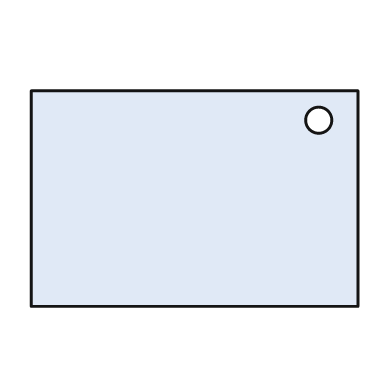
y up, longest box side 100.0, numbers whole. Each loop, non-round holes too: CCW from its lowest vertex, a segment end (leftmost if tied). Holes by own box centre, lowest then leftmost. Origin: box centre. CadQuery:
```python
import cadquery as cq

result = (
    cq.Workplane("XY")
    .moveTo(-50.0, -33.0)
    .lineTo(50.0, -33.0)
    .lineTo(50.0, 33.0)
    .lineTo(-50.0, 33.0)
    .close()
    .moveTo(38.0, 24.0)
    .circle(4.0)
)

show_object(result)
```